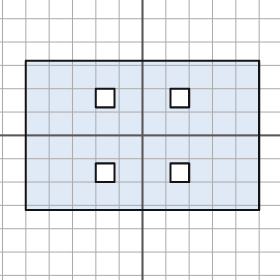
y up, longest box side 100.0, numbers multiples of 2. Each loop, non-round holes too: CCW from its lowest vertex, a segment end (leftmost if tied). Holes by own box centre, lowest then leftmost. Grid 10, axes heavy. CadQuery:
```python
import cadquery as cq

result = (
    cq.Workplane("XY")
    .moveTo(-50.0, -32.0)
    .lineTo(50.0, -32.0)
    .lineTo(50.0, 32.0)
    .lineTo(-50.0, 32.0)
    .close()
    .moveTo(-20.0, -20.0)
    .lineTo(-12.0, -20.0)
    .lineTo(-12.0, -12.0)
    .lineTo(-20.0, -12.0)
    .close()
    .moveTo(12.0, -20.0)
    .lineTo(20.0, -20.0)
    .lineTo(20.0, -12.0)
    .lineTo(12.0, -12.0)
    .close()
    .moveTo(-20.0, 12.0)
    .lineTo(-12.0, 12.0)
    .lineTo(-12.0, 20.0)
    .lineTo(-20.0, 20.0)
    .close()
    .moveTo(12.0, 12.0)
    .lineTo(20.0, 12.0)
    .lineTo(20.0, 20.0)
    .lineTo(12.0, 20.0)
    .close()
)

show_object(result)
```